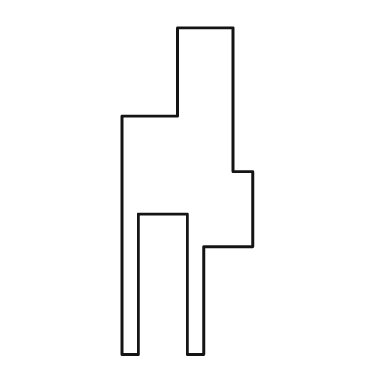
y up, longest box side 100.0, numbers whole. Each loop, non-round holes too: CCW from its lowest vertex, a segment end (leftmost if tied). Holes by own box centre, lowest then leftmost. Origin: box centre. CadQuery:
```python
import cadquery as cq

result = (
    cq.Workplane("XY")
    .moveTo(-20.0, -50.0)
    .lineTo(-15.0, -50.0)
    .lineTo(-15.0, -7.0)
    .lineTo(0.0, -7.0)
    .lineTo(0.0, -50.0)
    .lineTo(5.0, -50.0)
    .lineTo(5.0, -17.0)
    .lineTo(20.0, -17.0)
    .lineTo(20.0, 6.0)
    .lineTo(14.0, 6.0)
    .lineTo(14.0, 50.0)
    .lineTo(-3.0, 50.0)
    .lineTo(-3.0, 23.0)
    .lineTo(-20.0, 23.0)
    .close()
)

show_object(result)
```